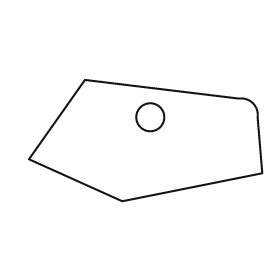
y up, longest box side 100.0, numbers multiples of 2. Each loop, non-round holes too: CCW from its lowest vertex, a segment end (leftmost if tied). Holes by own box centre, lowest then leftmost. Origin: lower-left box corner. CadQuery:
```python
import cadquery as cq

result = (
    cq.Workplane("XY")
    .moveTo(40.0, 0.0)
    .lineTo(100.0, 12.0)
    .lineTo(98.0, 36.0)
    .threePointArc((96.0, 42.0), (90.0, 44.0))
    .lineTo(24.0, 52.0)
    .lineTo(0.0, 18.0)
    .close()
    .moveTo(52.0, 36.0)
    .circle(6.0)
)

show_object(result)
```